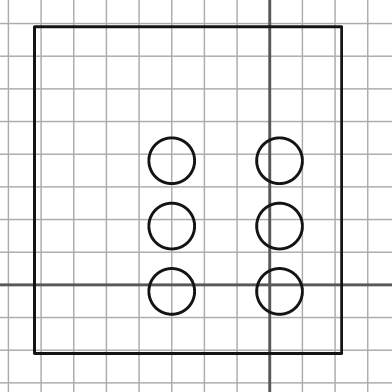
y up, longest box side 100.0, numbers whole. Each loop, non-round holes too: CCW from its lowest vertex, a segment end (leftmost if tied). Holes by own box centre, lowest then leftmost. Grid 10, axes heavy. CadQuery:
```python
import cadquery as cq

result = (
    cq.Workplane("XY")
    .moveTo(-72.0, -21.0)
    .lineTo(22.0, -21.0)
    .lineTo(22.0, 79.0)
    .lineTo(-72.0, 79.0)
    .close()
    .moveTo(-30.0, -2.0)
    .circle(7.0)
    .moveTo(3.0, -2.0)
    .circle(7.0)
    .moveTo(-30.0, 18.0)
    .circle(7.0)
    .moveTo(3.0, 18.0)
    .circle(7.0)
    .moveTo(-30.0, 38.0)
    .circle(7.0)
    .moveTo(3.0, 38.0)
    .circle(7.0)
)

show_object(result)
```